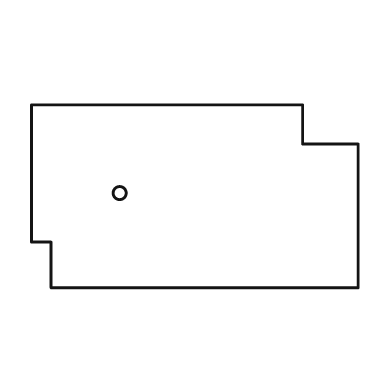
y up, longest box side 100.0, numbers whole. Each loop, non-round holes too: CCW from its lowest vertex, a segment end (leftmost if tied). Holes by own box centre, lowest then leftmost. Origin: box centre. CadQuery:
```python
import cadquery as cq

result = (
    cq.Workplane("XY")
    .moveTo(-44.0, -28.0)
    .lineTo(50.0, -28.0)
    .lineTo(50.0, 16.0)
    .lineTo(33.0, 16.0)
    .lineTo(33.0, 28.0)
    .lineTo(-50.0, 28.0)
    .lineTo(-50.0, -14.0)
    .lineTo(-44.0, -14.0)
    .close()
    .moveTo(-23.0, 1.0)
    .circle(2.0)
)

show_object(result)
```